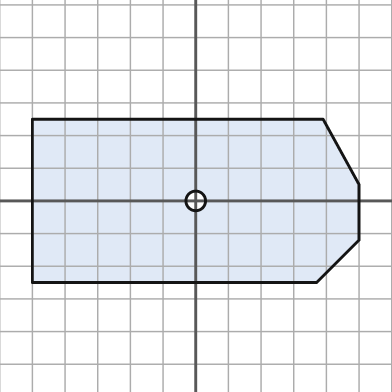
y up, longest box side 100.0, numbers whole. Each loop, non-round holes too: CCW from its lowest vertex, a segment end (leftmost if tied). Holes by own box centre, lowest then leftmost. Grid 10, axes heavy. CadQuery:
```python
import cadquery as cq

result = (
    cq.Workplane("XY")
    .moveTo(-50.0, -25.0)
    .lineTo(37.0, -25.0)
    .lineTo(50.0, -12.0)
    .lineTo(50.0, 5.0)
    .lineTo(39.0, 25.0)
    .lineTo(-50.0, 25.0)
    .close()
    .moveTo(0.0, 0.0)
    .circle(3.0)
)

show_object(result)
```